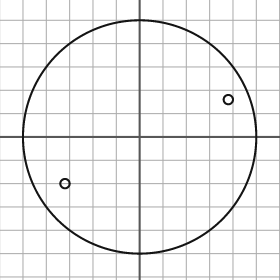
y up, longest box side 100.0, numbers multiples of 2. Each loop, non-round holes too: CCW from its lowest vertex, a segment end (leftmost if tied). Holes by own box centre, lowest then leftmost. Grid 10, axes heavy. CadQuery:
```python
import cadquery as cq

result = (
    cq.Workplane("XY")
    .moveTo(0.0, 0.0)
    .circle(50.0)
    .moveTo(-32.0, -20.0)
    .circle(2.0)
    .moveTo(38.0, 16.0)
    .circle(2.0)
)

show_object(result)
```